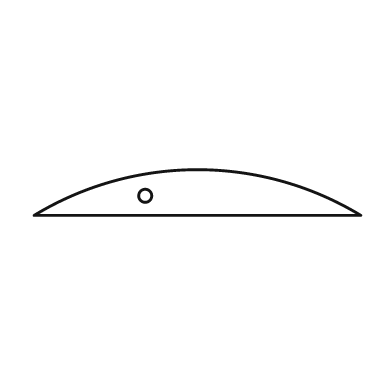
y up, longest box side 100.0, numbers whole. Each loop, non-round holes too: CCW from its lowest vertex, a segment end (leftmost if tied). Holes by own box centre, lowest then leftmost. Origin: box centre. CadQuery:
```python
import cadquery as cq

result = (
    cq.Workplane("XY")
    .moveTo(-50.0, -7.0)
    .lineTo(50.0, -7.0)
    .threePointArc((0.0, 7.0), (-50.0, -7.0))
    .close()
    .moveTo(-16.0, -1.0)
    .circle(2.0)
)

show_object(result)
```